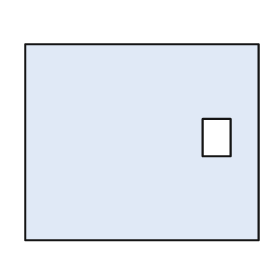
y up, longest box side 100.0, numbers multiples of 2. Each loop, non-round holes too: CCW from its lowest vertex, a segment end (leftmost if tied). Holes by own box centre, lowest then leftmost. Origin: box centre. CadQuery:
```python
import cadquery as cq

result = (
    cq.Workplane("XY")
    .moveTo(-50.0, -42.0)
    .lineTo(50.0, -42.0)
    .lineTo(50.0, 42.0)
    .lineTo(-50.0, 42.0)
    .close()
    .moveTo(26.0, -6.0)
    .lineTo(38.0, -6.0)
    .lineTo(38.0, 10.0)
    .lineTo(26.0, 10.0)
    .close()
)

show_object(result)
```